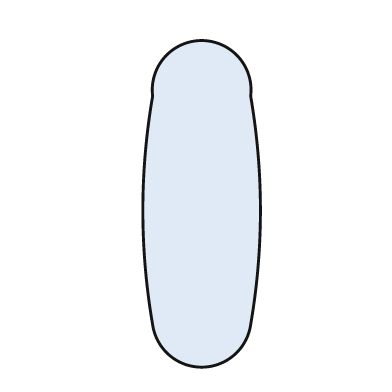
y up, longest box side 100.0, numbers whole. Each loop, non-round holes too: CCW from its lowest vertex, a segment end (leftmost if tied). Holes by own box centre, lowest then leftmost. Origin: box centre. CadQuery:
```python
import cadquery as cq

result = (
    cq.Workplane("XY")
    .moveTo(-15.0, -37.0)
    .threePointArc((0.0, -50.0), (15.0, -37.0))
    .threePointArc((18.0, -2.0), (15.0, 33.0))
    .threePointArc((0.0, 50.0), (-15.0, 33.0))
    .threePointArc((-18.0, -2.0), (-15.0, -37.0))
    .close()
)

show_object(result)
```